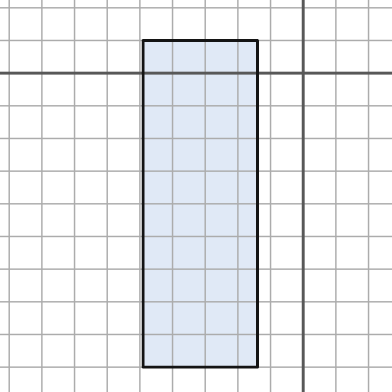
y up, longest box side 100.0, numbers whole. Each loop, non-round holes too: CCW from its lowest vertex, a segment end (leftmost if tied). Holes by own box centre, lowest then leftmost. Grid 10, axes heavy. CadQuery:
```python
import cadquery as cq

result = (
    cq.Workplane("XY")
    .moveTo(-49.0, -90.0)
    .lineTo(-14.0, -90.0)
    .lineTo(-14.0, 10.0)
    .lineTo(-49.0, 10.0)
    .close()
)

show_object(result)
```